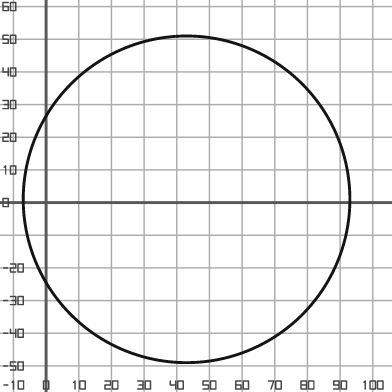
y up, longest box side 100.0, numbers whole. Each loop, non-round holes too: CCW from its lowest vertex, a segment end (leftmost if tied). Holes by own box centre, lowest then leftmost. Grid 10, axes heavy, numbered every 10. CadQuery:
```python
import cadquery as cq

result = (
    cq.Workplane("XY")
    .moveTo(43.0, 1.0)
    .circle(50.0)
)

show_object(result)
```